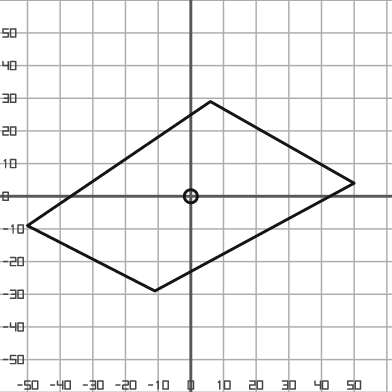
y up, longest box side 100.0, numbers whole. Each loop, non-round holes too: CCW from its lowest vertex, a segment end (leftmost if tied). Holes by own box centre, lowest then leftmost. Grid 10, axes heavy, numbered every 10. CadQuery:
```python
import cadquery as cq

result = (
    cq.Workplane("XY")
    .moveTo(-11.0, -29.0)
    .lineTo(50.0, 4.0)
    .lineTo(6.0, 29.0)
    .lineTo(-50.0, -9.0)
    .close()
    .moveTo(0.0, 0.0)
    .circle(2.0)
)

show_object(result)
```